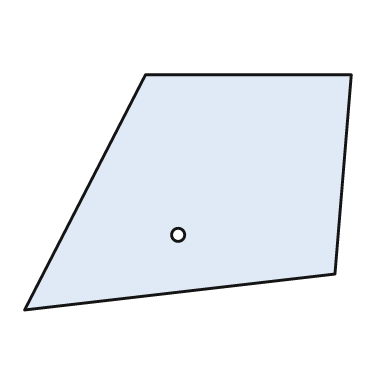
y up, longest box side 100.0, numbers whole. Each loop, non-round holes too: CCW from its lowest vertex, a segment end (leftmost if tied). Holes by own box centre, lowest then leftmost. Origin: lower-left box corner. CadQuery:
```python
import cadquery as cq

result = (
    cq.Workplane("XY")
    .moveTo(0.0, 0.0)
    .lineTo(95.0, 11.0)
    .lineTo(100.0, 72.0)
    .lineTo(37.0, 72.0)
    .close()
    .moveTo(47.0, 23.0)
    .circle(2.0)
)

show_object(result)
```